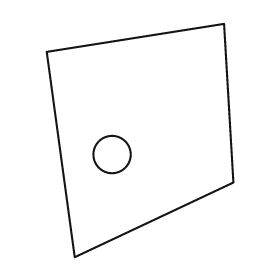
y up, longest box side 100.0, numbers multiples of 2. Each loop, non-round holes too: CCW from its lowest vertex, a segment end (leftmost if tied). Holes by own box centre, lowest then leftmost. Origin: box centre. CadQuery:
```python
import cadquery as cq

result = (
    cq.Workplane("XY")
    .moveTo(-28.0, -50.0)
    .lineTo(40.0, -18.0)
    .lineTo(36.0, 50.0)
    .lineTo(-40.0, 38.0)
    .close()
    .moveTo(-12.0, -6.0)
    .circle(8.0)
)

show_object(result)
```